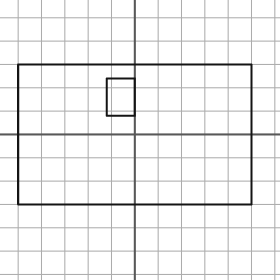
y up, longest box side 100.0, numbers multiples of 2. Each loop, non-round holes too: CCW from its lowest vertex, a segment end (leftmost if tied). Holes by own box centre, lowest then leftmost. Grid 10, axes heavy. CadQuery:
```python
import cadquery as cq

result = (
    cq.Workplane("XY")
    .moveTo(-50.0, -30.0)
    .lineTo(50.0, -30.0)
    .lineTo(50.0, 30.0)
    .lineTo(-50.0, 30.0)
    .close()
    .moveTo(-12.0, 8.0)
    .lineTo(0.0, 8.0)
    .lineTo(0.0, 24.0)
    .lineTo(-12.0, 24.0)
    .close()
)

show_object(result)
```